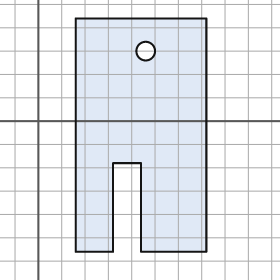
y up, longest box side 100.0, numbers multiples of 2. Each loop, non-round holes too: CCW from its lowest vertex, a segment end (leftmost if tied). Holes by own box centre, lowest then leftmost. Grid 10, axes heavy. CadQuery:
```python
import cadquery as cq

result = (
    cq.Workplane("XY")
    .moveTo(16.0, -56.0)
    .lineTo(32.0, -56.0)
    .lineTo(32.0, -18.0)
    .lineTo(44.0, -18.0)
    .lineTo(44.0, -56.0)
    .lineTo(72.0, -56.0)
    .lineTo(72.0, 44.0)
    .lineTo(16.0, 44.0)
    .close()
    .moveTo(46.0, 30.0)
    .circle(4.0)
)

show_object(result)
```